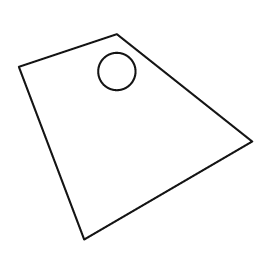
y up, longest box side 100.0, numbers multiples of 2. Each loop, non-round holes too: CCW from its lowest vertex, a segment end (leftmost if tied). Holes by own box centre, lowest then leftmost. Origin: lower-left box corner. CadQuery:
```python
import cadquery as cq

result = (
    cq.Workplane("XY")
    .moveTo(28.0, 0.0)
    .lineTo(100.0, 42.0)
    .lineTo(42.0, 88.0)
    .lineTo(0.0, 74.0)
    .close()
    .moveTo(42.0, 72.0)
    .circle(8.0)
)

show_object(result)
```